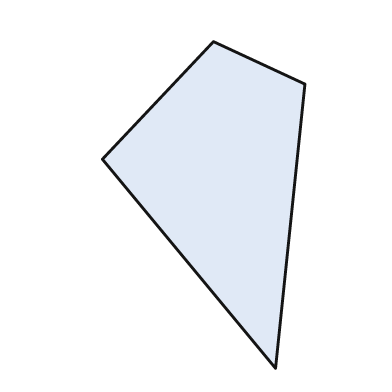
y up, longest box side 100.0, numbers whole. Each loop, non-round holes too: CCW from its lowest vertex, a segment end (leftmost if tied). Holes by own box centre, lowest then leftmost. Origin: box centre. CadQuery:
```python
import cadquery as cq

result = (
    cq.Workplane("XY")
    .moveTo(22.0, -50.0)
    .lineTo(31.0, 37.0)
    .lineTo(3.0, 50.0)
    .lineTo(-31.0, 14.0)
    .close()
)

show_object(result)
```